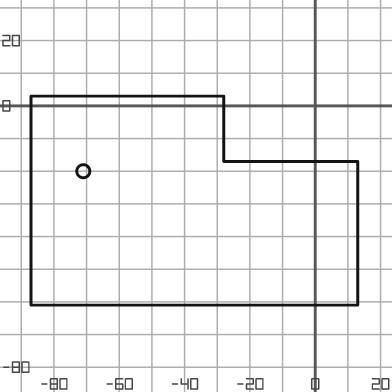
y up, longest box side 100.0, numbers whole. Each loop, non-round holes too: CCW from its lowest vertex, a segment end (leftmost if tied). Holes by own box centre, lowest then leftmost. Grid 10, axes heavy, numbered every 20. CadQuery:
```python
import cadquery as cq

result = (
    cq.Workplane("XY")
    .moveTo(-87.0, -61.0)
    .lineTo(13.0, -61.0)
    .lineTo(13.0, -17.0)
    .lineTo(-28.0, -17.0)
    .lineTo(-28.0, 3.0)
    .lineTo(-87.0, 3.0)
    .close()
    .moveTo(-71.0, -20.0)
    .circle(2.0)
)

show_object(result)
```